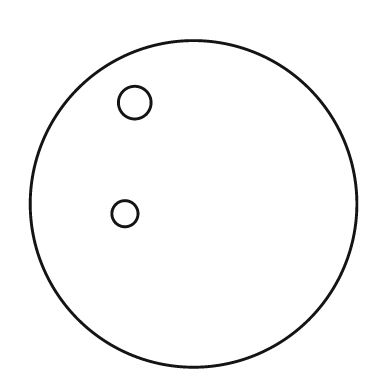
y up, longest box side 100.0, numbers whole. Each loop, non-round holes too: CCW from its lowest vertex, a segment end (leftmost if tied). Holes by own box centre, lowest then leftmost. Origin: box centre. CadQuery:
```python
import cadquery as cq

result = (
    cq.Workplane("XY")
    .moveTo(0.0, 0.0)
    .circle(50.0)
    .moveTo(-21.0, -3.0)
    .circle(4.0)
    .moveTo(-18.0, 31.0)
    .circle(5.0)
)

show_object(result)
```